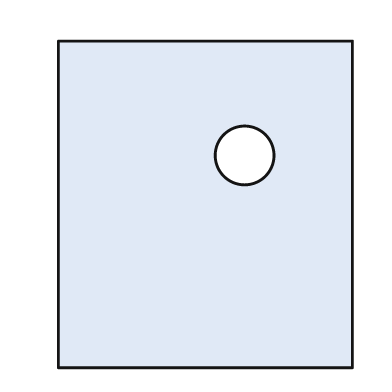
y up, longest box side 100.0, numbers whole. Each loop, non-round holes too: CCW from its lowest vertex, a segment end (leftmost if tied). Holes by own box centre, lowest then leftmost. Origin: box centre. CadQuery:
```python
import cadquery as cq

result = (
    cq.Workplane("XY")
    .moveTo(-45.0, -50.0)
    .lineTo(45.0, -50.0)
    .lineTo(45.0, 50.0)
    .lineTo(-45.0, 50.0)
    .close()
    .moveTo(12.0, 15.0)
    .circle(9.0)
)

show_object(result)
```